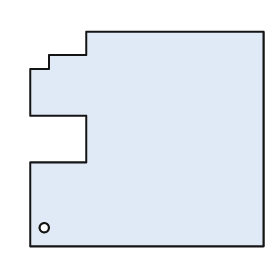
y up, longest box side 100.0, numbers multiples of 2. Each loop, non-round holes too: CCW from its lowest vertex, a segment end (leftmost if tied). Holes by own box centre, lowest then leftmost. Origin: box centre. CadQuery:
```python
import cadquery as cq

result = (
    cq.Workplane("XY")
    .moveTo(-50.0, -46.0)
    .lineTo(50.0, -46.0)
    .lineTo(50.0, 46.0)
    .lineTo(-26.0, 46.0)
    .lineTo(-26.0, 36.0)
    .lineTo(-42.0, 36.0)
    .lineTo(-42.0, 30.0)
    .lineTo(-50.0, 30.0)
    .lineTo(-50.0, 10.0)
    .lineTo(-26.0, 10.0)
    .lineTo(-26.0, -10.0)
    .lineTo(-50.0, -10.0)
    .close()
    .moveTo(-44.0, -38.0)
    .circle(2.0)
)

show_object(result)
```